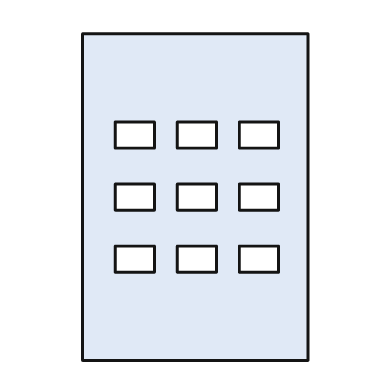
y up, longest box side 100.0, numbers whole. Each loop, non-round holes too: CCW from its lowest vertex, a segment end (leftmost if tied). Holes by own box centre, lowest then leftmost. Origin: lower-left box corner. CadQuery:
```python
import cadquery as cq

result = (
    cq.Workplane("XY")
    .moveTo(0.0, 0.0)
    .lineTo(69.0, 0.0)
    .lineTo(69.0, 100.0)
    .lineTo(0.0, 100.0)
    .close()
    .moveTo(10.0, 27.0)
    .lineTo(22.0, 27.0)
    .lineTo(22.0, 35.0)
    .lineTo(10.0, 35.0)
    .close()
    .moveTo(29.0, 27.0)
    .lineTo(41.0, 27.0)
    .lineTo(41.0, 35.0)
    .lineTo(29.0, 35.0)
    .close()
    .moveTo(48.0, 27.0)
    .lineTo(60.0, 27.0)
    .lineTo(60.0, 35.0)
    .lineTo(48.0, 35.0)
    .close()
    .moveTo(10.0, 46.0)
    .lineTo(22.0, 46.0)
    .lineTo(22.0, 54.0)
    .lineTo(10.0, 54.0)
    .close()
    .moveTo(29.0, 46.0)
    .lineTo(41.0, 46.0)
    .lineTo(41.0, 54.0)
    .lineTo(29.0, 54.0)
    .close()
    .moveTo(48.0, 46.0)
    .lineTo(60.0, 46.0)
    .lineTo(60.0, 54.0)
    .lineTo(48.0, 54.0)
    .close()
    .moveTo(10.0, 65.0)
    .lineTo(22.0, 65.0)
    .lineTo(22.0, 73.0)
    .lineTo(10.0, 73.0)
    .close()
    .moveTo(29.0, 65.0)
    .lineTo(41.0, 65.0)
    .lineTo(41.0, 73.0)
    .lineTo(29.0, 73.0)
    .close()
    .moveTo(48.0, 65.0)
    .lineTo(60.0, 65.0)
    .lineTo(60.0, 73.0)
    .lineTo(48.0, 73.0)
    .close()
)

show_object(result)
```